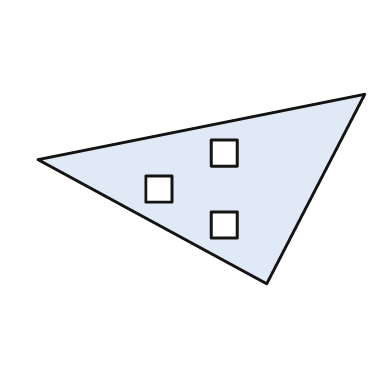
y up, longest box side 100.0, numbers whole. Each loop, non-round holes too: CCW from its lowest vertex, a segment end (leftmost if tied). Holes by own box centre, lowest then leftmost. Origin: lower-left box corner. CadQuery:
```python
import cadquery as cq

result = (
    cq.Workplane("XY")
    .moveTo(70.0, 0.0)
    .lineTo(100.0, 58.0)
    .lineTo(0.0, 38.0)
    .close()
    .moveTo(53.0, 14.0)
    .lineTo(61.0, 14.0)
    .lineTo(61.0, 22.0)
    .lineTo(53.0, 22.0)
    .close()
    .moveTo(33.0, 25.0)
    .lineTo(41.0, 25.0)
    .lineTo(41.0, 33.0)
    .lineTo(33.0, 33.0)
    .close()
    .moveTo(53.0, 36.0)
    .lineTo(61.0, 36.0)
    .lineTo(61.0, 44.0)
    .lineTo(53.0, 44.0)
    .close()
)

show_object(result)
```